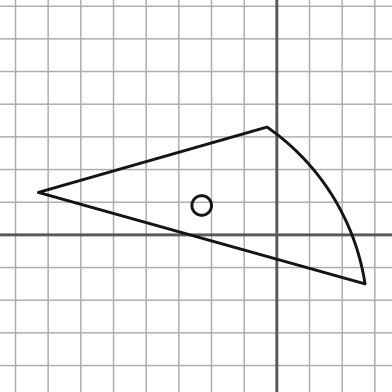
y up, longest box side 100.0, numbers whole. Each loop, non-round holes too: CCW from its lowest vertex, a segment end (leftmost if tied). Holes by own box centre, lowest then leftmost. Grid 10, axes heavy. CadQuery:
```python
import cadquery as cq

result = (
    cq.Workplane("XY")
    .moveTo(27.0, -15.0)
    .threePointArc((17.0, 12.0), (-3.0, 33.0))
    .lineTo(-73.0, 13.0)
    .close()
    .moveTo(-23.0, 9.0)
    .circle(3.0)
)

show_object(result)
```